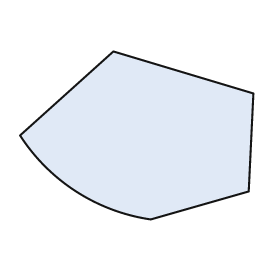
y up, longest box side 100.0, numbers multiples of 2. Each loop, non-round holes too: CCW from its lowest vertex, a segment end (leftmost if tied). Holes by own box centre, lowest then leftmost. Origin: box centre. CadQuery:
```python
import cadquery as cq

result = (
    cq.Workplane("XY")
    .moveTo(6.0, -36.0)
    .lineTo(48.0, -24.0)
    .lineTo(50.0, 18.0)
    .lineTo(-10.0, 36.0)
    .lineTo(-50.0, 0.0)
    .threePointArc((-26.0, -24.0), (6.0, -36.0))
    .close()
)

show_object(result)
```